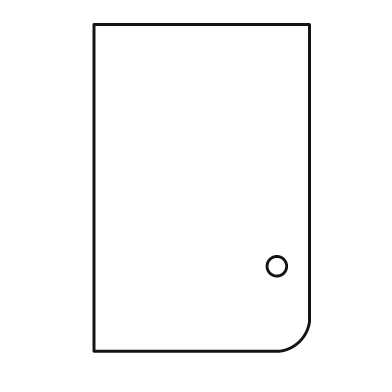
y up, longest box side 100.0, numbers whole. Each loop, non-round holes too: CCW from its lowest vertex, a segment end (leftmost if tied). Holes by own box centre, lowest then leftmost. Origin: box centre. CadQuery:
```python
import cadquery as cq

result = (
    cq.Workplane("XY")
    .moveTo(-33.0, -50.0)
    .lineTo(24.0, -50.0)
    .threePointArc((30.0, -47.0), (33.0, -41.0))
    .lineTo(33.0, 50.0)
    .lineTo(-33.0, 50.0)
    .close()
    .moveTo(23.0, -24.0)
    .circle(3.0)
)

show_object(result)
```